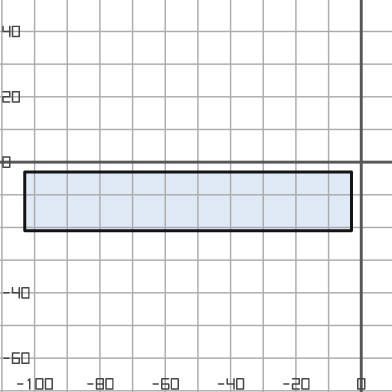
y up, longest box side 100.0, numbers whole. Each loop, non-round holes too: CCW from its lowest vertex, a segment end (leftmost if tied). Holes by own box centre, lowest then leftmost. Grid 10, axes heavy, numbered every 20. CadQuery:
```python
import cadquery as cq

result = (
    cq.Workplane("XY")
    .moveTo(-103.0, -21.0)
    .lineTo(-3.0, -21.0)
    .lineTo(-3.0, -3.0)
    .lineTo(-103.0, -3.0)
    .close()
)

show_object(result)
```